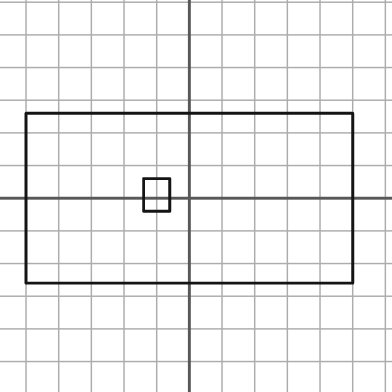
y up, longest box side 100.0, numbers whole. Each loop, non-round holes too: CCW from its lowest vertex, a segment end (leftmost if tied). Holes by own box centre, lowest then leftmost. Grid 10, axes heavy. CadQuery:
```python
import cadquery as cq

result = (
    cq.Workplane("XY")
    .moveTo(-50.0, -26.0)
    .lineTo(50.0, -26.0)
    .lineTo(50.0, 26.0)
    .lineTo(-50.0, 26.0)
    .close()
    .moveTo(-14.0, -4.0)
    .lineTo(-6.0, -4.0)
    .lineTo(-6.0, 6.0)
    .lineTo(-14.0, 6.0)
    .close()
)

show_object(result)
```